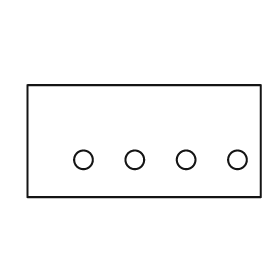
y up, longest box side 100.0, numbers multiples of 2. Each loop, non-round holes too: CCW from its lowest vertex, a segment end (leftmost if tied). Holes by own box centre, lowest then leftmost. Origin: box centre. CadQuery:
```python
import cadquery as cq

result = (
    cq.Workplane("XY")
    .moveTo(-50.0, -24.0)
    .lineTo(50.0, -24.0)
    .lineTo(50.0, 24.0)
    .lineTo(-50.0, 24.0)
    .close()
    .moveTo(-26.0, -8.0)
    .circle(4.0)
    .moveTo(-4.0, -8.0)
    .circle(4.0)
    .moveTo(18.0, -8.0)
    .circle(4.0)
    .moveTo(40.0, -8.0)
    .circle(4.0)
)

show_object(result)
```